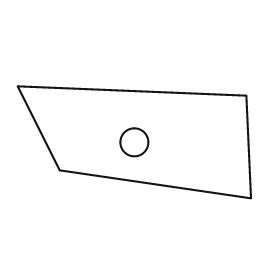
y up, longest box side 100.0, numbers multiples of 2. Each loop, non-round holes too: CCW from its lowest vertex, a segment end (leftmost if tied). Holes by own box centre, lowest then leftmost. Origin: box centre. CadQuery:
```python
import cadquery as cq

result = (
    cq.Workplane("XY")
    .moveTo(50.0, -24.0)
    .lineTo(48.0, 20.0)
    .lineTo(-50.0, 24.0)
    .lineTo(-32.0, -12.0)
    .close()
    .moveTo(0.0, 0.0)
    .circle(6.0)
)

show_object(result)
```